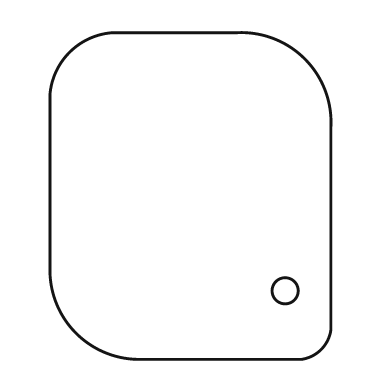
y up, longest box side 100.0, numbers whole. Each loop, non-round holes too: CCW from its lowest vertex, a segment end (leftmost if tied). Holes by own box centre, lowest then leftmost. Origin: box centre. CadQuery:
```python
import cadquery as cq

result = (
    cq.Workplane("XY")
    .moveTo(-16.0, -50.0)
    .lineTo(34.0, -50.0)
    .threePointArc((40.0, -47.0), (43.0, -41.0))
    .lineTo(43.0, 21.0)
    .threePointArc((35.0, 42.0), (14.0, 50.0))
    .lineTo(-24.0, 50.0)
    .threePointArc((-37.0, 44.0), (-43.0, 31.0))
    .lineTo(-43.0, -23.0)
    .threePointArc((-35.0, -42.0), (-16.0, -50.0))
    .close()
    .moveTo(29.0, -29.0)
    .circle(4.0)
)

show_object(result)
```